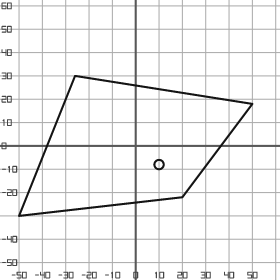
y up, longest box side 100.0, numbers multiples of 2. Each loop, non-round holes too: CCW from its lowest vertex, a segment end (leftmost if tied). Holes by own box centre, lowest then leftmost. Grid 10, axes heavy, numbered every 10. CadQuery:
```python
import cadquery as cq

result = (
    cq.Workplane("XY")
    .moveTo(-50.0, -30.0)
    .lineTo(20.0, -22.0)
    .lineTo(50.0, 18.0)
    .lineTo(-26.0, 30.0)
    .close()
    .moveTo(10.0, -8.0)
    .circle(2.0)
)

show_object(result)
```